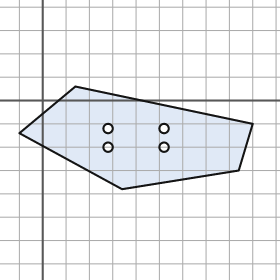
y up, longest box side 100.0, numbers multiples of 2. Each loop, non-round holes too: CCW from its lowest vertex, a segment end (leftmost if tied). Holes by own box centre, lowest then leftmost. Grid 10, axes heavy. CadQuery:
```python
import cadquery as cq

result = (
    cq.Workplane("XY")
    .moveTo(34.0, -38.0)
    .lineTo(84.0, -30.0)
    .lineTo(90.0, -10.0)
    .lineTo(14.0, 6.0)
    .lineTo(-10.0, -14.0)
    .close()
    .moveTo(28.0, -20.0)
    .circle(2.0)
    .moveTo(52.0, -20.0)
    .circle(2.0)
    .moveTo(28.0, -12.0)
    .circle(2.0)
    .moveTo(52.0, -12.0)
    .circle(2.0)
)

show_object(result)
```